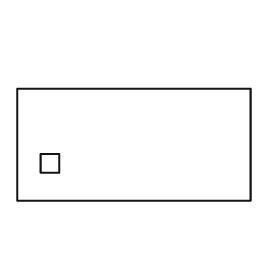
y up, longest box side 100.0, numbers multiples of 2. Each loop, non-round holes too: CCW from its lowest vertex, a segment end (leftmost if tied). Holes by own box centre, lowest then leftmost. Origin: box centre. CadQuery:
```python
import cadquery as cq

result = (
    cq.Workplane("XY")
    .moveTo(-50.0, -24.0)
    .lineTo(50.0, -24.0)
    .lineTo(50.0, 24.0)
    .lineTo(-50.0, 24.0)
    .close()
    .moveTo(-40.0, -12.0)
    .lineTo(-32.0, -12.0)
    .lineTo(-32.0, -4.0)
    .lineTo(-40.0, -4.0)
    .close()
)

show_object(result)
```